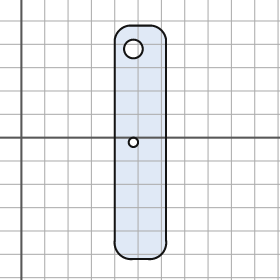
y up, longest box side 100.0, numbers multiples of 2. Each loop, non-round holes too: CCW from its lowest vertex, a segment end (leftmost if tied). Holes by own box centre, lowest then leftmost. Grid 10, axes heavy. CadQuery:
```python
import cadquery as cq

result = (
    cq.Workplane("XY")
    .moveTo(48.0, -52.0)
    .lineTo(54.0, -52.0)
    .threePointArc((60.0, -50.0), (62.0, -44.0))
    .lineTo(62.0, 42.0)
    .threePointArc((60.0, 46.0), (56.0, 48.0))
    .lineTo(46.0, 48.0)
    .threePointArc((42.0, 46.0), (40.0, 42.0))
    .lineTo(40.0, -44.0)
    .threePointArc((42.0, -50.0), (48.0, -52.0))
    .close()
    .moveTo(48.0, -2.0)
    .circle(2.0)
    .moveTo(48.0, 38.0)
    .circle(4.0)
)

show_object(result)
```